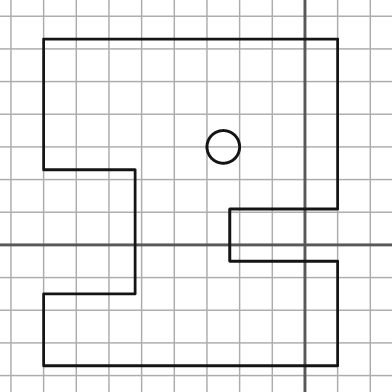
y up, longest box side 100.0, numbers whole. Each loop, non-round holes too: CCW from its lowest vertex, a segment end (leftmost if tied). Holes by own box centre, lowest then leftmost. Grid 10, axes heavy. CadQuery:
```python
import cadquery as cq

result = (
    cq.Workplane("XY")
    .moveTo(-80.0, -37.0)
    .lineTo(10.0, -37.0)
    .lineTo(10.0, -5.0)
    .lineTo(-23.0, -5.0)
    .lineTo(-23.0, 11.0)
    .lineTo(10.0, 11.0)
    .lineTo(10.0, 63.0)
    .lineTo(-80.0, 63.0)
    .lineTo(-80.0, 23.0)
    .lineTo(-52.0, 23.0)
    .lineTo(-52.0, -15.0)
    .lineTo(-80.0, -15.0)
    .close()
    .moveTo(-25.0, 30.0)
    .circle(5.0)
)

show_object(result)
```